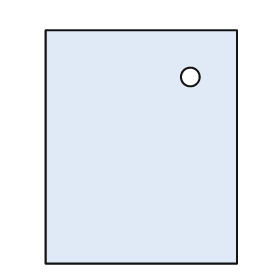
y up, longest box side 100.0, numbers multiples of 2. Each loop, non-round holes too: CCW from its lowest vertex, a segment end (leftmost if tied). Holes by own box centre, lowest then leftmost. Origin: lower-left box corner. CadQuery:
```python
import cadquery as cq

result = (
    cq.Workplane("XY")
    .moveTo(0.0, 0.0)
    .lineTo(82.0, 0.0)
    .lineTo(82.0, 100.0)
    .lineTo(0.0, 100.0)
    .close()
    .moveTo(62.0, 80.0)
    .circle(4.0)
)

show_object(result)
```